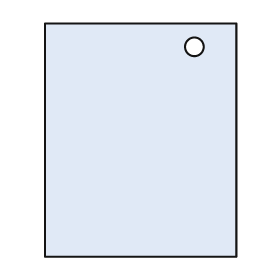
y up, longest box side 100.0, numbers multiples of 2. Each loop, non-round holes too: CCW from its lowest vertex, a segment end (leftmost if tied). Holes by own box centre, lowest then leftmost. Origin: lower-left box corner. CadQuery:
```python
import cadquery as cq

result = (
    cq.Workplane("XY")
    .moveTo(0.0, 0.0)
    .lineTo(82.0, 0.0)
    .lineTo(82.0, 100.0)
    .lineTo(0.0, 100.0)
    .close()
    .moveTo(64.0, 90.0)
    .circle(4.0)
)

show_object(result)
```